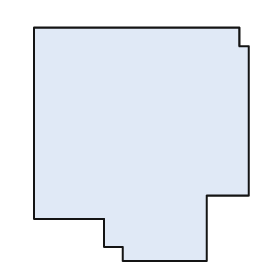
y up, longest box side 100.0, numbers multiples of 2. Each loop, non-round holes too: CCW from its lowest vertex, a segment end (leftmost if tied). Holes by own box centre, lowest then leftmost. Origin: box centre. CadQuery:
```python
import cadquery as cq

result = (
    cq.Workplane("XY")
    .moveTo(-8.0, -50.0)
    .lineTo(28.0, -50.0)
    .lineTo(28.0, -22.0)
    .lineTo(46.0, -22.0)
    .lineTo(46.0, 42.0)
    .lineTo(42.0, 42.0)
    .lineTo(42.0, 50.0)
    .lineTo(-46.0, 50.0)
    .lineTo(-46.0, -32.0)
    .lineTo(-16.0, -32.0)
    .lineTo(-16.0, -44.0)
    .lineTo(-8.0, -44.0)
    .close()
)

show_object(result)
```